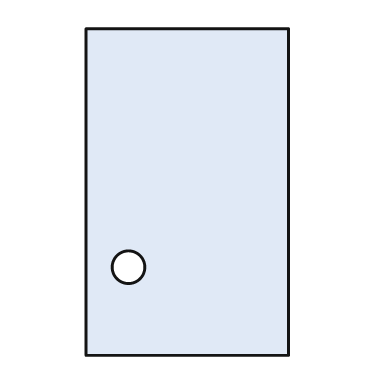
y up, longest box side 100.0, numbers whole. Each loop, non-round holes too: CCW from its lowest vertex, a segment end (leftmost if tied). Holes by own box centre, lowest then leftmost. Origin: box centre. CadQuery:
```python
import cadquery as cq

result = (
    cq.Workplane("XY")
    .moveTo(-31.0, -50.0)
    .lineTo(31.0, -50.0)
    .lineTo(31.0, 50.0)
    .lineTo(-31.0, 50.0)
    .close()
    .moveTo(-18.0, -23.0)
    .circle(5.0)
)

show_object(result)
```